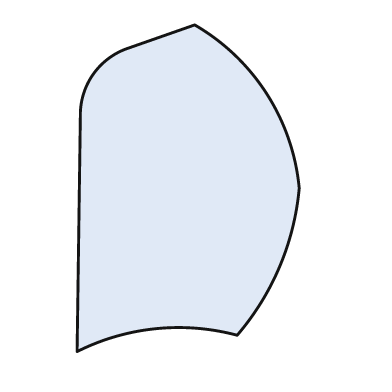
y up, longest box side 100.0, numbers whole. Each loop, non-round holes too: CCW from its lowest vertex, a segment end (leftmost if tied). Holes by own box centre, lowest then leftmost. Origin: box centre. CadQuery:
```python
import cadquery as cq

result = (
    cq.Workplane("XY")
    .moveTo(-34.0, -50.0)
    .threePointArc((-10.0, -43.0), (15.0, -45.0))
    .threePointArc((28.0, -24.0), (34.0, 0.0))
    .threePointArc((24.0, 29.0), (2.0, 50.0))
    .lineTo(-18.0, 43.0)
    .threePointArc((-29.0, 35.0), (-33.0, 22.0))
    .close()
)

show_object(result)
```